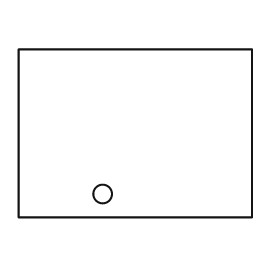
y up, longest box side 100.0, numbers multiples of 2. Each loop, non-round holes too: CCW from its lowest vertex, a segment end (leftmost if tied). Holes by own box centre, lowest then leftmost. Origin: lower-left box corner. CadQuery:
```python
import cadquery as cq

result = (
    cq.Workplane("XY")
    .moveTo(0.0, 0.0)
    .lineTo(100.0, 0.0)
    .lineTo(100.0, 72.0)
    .lineTo(0.0, 72.0)
    .close()
    .moveTo(36.0, 10.0)
    .circle(4.0)
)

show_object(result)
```